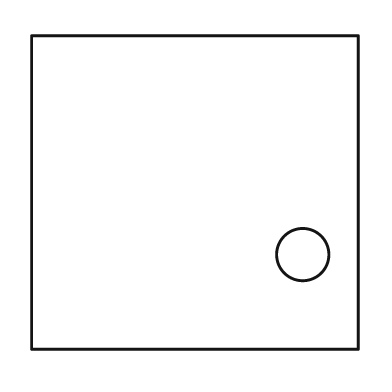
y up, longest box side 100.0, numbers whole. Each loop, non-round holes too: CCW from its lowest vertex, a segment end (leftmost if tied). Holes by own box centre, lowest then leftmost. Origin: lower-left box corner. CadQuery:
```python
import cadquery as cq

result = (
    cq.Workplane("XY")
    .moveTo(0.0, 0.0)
    .lineTo(100.0, 0.0)
    .lineTo(100.0, 96.0)
    .lineTo(0.0, 96.0)
    .close()
    .moveTo(83.0, 29.0)
    .circle(8.0)
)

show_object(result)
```